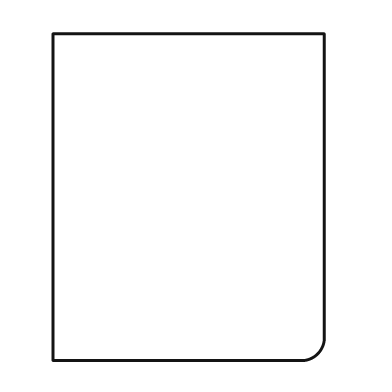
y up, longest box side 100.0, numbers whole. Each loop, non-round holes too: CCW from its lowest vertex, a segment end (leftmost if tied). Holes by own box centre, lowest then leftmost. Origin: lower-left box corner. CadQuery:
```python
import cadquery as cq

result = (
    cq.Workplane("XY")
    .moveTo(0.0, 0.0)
    .lineTo(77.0, 0.0)
    .threePointArc((81.0, 2.0), (83.0, 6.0))
    .lineTo(83.0, 100.0)
    .lineTo(0.0, 100.0)
    .close()
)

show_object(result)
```